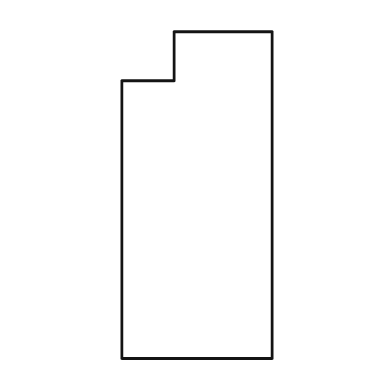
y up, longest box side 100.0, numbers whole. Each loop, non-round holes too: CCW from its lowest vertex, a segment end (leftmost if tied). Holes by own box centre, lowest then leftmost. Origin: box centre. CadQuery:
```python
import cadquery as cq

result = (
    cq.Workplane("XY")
    .moveTo(-23.0, -50.0)
    .lineTo(23.0, -50.0)
    .lineTo(23.0, 50.0)
    .lineTo(-7.0, 50.0)
    .lineTo(-7.0, 35.0)
    .lineTo(-23.0, 35.0)
    .close()
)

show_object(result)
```